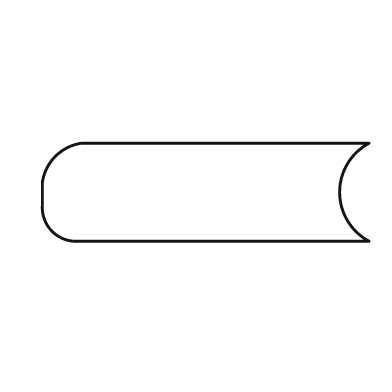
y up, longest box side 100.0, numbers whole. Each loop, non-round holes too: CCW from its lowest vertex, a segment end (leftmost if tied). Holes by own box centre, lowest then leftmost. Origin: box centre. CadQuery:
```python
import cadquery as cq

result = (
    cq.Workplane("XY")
    .moveTo(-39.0, -15.0)
    .lineTo(50.0, -15.0)
    .threePointArc((41.0, 0.0), (50.0, 15.0))
    .lineTo(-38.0, 15.0)
    .threePointArc((-46.0, 11.0), (-50.0, 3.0))
    .lineTo(-50.0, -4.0)
    .threePointArc((-47.0, -12.0), (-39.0, -15.0))
    .close()
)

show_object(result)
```